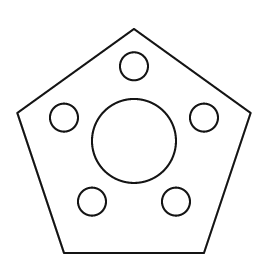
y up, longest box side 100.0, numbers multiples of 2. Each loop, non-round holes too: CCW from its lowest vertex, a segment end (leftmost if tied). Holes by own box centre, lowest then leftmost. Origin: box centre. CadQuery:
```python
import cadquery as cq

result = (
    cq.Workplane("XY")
    .moveTo(-30.0, -48.0)
    .lineTo(30.0, -48.0)
    .lineTo(50.0, 12.0)
    .lineTo(0.0, 48.0)
    .lineTo(-50.0, 12.0)
    .close()
    .moveTo(-18.0, -26.0)
    .circle(6.0)
    .moveTo(18.0, -26.0)
    .circle(6.0)
    .moveTo(0.0, 0.0)
    .circle(18.0)
    .moveTo(-30.0, 10.0)
    .circle(6.0)
    .moveTo(30.0, 10.0)
    .circle(6.0)
    .moveTo(0.0, 32.0)
    .circle(6.0)
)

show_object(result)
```